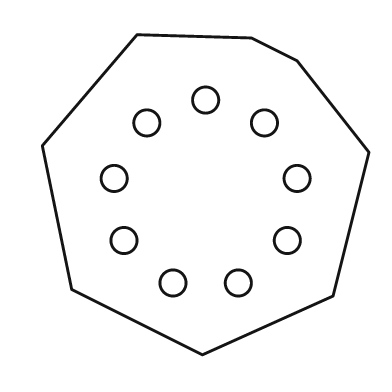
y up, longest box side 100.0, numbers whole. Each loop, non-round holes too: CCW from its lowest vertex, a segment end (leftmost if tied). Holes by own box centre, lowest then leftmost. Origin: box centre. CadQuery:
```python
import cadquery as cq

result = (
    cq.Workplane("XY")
    .moveTo(-1.0, -49.0)
    .lineTo(39.0, -31.0)
    .lineTo(50.0, 13.0)
    .lineTo(28.0, 41.0)
    .lineTo(14.0, 48.0)
    .lineTo(-21.0, 49.0)
    .lineTo(-50.0, 15.0)
    .lineTo(-41.0, -29.0)
    .close()
    .moveTo(-10.0, -27.0)
    .circle(4.0)
    .moveTo(10.0, -27.0)
    .circle(4.0)
    .moveTo(-25.0, -14.0)
    .circle(4.0)
    .moveTo(25.0, -14.0)
    .circle(4.0)
    .moveTo(-28.0, 5.0)
    .circle(4.0)
    .moveTo(28.0, 5.0)
    .circle(4.0)
    .moveTo(-18.0, 22.0)
    .circle(4.0)
    .moveTo(18.0, 22.0)
    .circle(4.0)
    .moveTo(0.0, 29.0)
    .circle(4.0)
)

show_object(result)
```